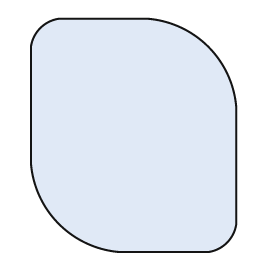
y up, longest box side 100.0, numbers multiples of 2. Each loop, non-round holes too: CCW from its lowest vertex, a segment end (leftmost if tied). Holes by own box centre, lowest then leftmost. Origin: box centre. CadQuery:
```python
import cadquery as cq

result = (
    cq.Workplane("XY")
    .moveTo(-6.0, -50.0)
    .lineTo(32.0, -50.0)
    .threePointArc((40.0, -46.0), (44.0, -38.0))
    .lineTo(44.0, 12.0)
    .threePointArc((32.0, 38.0), (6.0, 50.0))
    .lineTo(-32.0, 50.0)
    .threePointArc((-40.0, 46.0), (-44.0, 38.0))
    .lineTo(-44.0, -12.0)
    .threePointArc((-32.0, -38.0), (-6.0, -50.0))
    .close()
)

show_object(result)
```